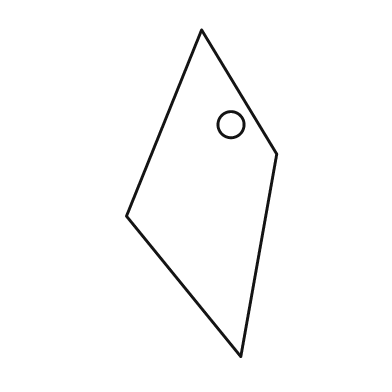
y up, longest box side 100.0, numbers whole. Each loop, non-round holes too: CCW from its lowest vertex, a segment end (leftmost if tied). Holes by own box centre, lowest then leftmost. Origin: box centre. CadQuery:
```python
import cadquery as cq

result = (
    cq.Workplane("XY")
    .moveTo(12.0, -50.0)
    .lineTo(23.0, 12.0)
    .lineTo(0.0, 50.0)
    .lineTo(-23.0, -7.0)
    .close()
    .moveTo(9.0, 21.0)
    .circle(4.0)
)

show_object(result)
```